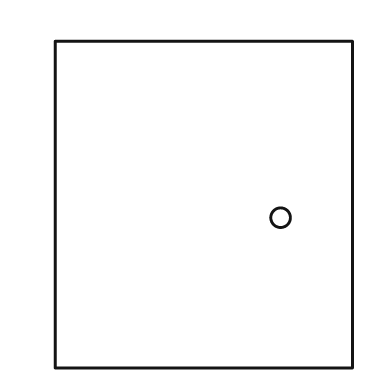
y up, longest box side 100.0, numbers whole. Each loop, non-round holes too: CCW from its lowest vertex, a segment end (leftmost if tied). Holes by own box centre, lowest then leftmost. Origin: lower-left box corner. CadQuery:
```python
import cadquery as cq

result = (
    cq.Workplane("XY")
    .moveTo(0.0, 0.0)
    .lineTo(91.0, 0.0)
    .lineTo(91.0, 100.0)
    .lineTo(0.0, 100.0)
    .close()
    .moveTo(69.0, 46.0)
    .circle(3.0)
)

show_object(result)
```